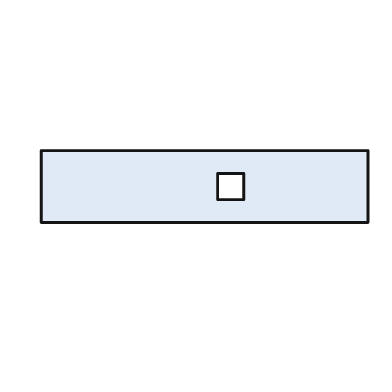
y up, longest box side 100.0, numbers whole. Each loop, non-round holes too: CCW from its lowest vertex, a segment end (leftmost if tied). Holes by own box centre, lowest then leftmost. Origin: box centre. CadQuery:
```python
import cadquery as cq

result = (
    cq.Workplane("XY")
    .moveTo(-50.0, -11.0)
    .lineTo(50.0, -11.0)
    .lineTo(50.0, 11.0)
    .lineTo(-50.0, 11.0)
    .close()
    .moveTo(4.0, -4.0)
    .lineTo(12.0, -4.0)
    .lineTo(12.0, 4.0)
    .lineTo(4.0, 4.0)
    .close()
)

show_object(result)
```